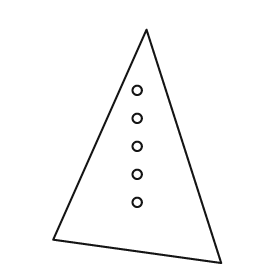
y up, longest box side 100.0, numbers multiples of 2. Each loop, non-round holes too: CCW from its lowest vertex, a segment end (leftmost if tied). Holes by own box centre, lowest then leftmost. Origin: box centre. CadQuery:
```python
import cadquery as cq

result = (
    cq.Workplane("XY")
    .moveTo(36.0, -50.0)
    .lineTo(4.0, 50.0)
    .lineTo(-36.0, -40.0)
    .close()
    .moveTo(0.0, -24.0)
    .circle(2.0)
    .moveTo(0.0, -12.0)
    .circle(2.0)
    .moveTo(0.0, 0.0)
    .circle(2.0)
    .moveTo(0.0, 12.0)
    .circle(2.0)
    .moveTo(0.0, 24.0)
    .circle(2.0)
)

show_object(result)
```